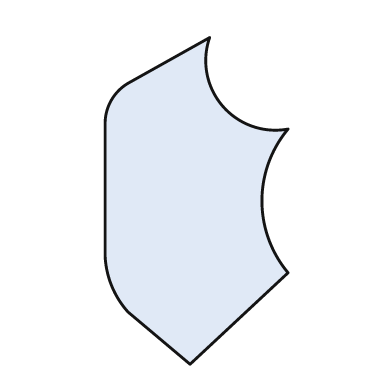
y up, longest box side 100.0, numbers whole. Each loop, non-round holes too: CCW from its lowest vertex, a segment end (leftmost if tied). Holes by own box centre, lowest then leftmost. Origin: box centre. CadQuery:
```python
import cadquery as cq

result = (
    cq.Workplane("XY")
    .moveTo(-2.0, -50.0)
    .lineTo(28.0, -22.0)
    .threePointArc((20.0, 0.0), (28.0, 22.0))
    .threePointArc((8.0, 29.0), (4.0, 50.0))
    .lineTo(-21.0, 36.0)
    .threePointArc((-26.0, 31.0), (-28.0, 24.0))
    .lineTo(-28.0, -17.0)
    .threePointArc((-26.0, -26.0), (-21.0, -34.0))
    .close()
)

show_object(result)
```